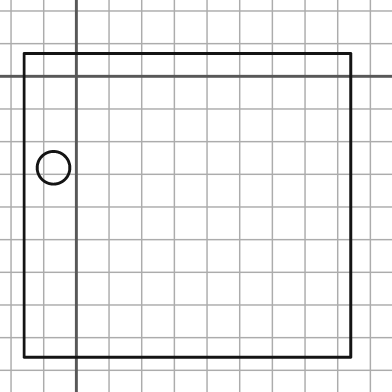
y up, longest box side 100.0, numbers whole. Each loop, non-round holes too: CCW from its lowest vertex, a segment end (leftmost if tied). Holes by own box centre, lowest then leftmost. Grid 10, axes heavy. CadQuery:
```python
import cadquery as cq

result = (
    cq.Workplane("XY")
    .moveTo(-16.0, -86.0)
    .lineTo(84.0, -86.0)
    .lineTo(84.0, 7.0)
    .lineTo(-16.0, 7.0)
    .close()
    .moveTo(-7.0, -28.0)
    .circle(5.0)
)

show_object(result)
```